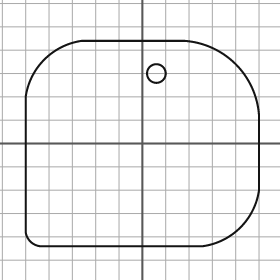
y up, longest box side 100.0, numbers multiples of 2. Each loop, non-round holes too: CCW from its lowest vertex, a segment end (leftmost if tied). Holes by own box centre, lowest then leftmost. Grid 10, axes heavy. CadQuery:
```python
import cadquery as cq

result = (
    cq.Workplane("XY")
    .moveTo(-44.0, -44.0)
    .lineTo(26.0, -44.0)
    .threePointArc((42.0, -36.0), (50.0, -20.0))
    .lineTo(50.0, 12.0)
    .threePointArc((40.0, 34.0), (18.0, 44.0))
    .lineTo(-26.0, 44.0)
    .threePointArc((-42.0, 36.0), (-50.0, 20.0))
    .lineTo(-50.0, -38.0)
    .threePointArc((-48.0, -42.0), (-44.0, -44.0))
    .close()
    .moveTo(6.0, 30.0)
    .circle(4.0)
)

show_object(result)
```